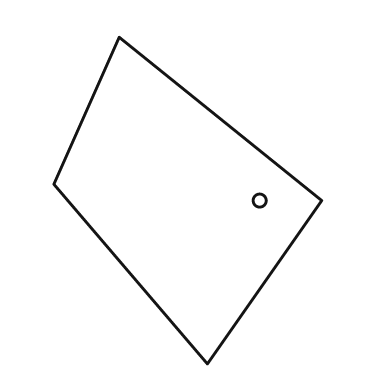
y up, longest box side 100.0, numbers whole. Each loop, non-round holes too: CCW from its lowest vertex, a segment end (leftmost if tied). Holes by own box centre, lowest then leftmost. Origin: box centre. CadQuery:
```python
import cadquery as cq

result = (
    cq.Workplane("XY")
    .moveTo(6.0, -50.0)
    .lineTo(41.0, 0.0)
    .lineTo(-21.0, 50.0)
    .lineTo(-41.0, 5.0)
    .close()
    .moveTo(22.0, 0.0)
    .circle(2.0)
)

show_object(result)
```